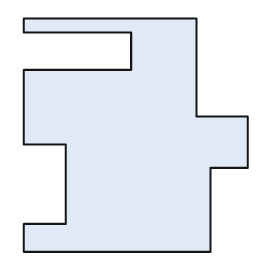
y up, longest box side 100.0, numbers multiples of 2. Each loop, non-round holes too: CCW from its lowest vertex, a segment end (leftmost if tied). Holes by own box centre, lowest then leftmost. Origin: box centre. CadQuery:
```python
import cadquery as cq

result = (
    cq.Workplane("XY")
    .moveTo(-48.0, -50.0)
    .lineTo(32.0, -50.0)
    .lineTo(32.0, -14.0)
    .lineTo(48.0, -14.0)
    .lineTo(48.0, 8.0)
    .lineTo(26.0, 8.0)
    .lineTo(26.0, 50.0)
    .lineTo(-48.0, 50.0)
    .lineTo(-48.0, 44.0)
    .lineTo(-2.0, 44.0)
    .lineTo(-2.0, 28.0)
    .lineTo(-48.0, 28.0)
    .lineTo(-48.0, -4.0)
    .lineTo(-30.0, -4.0)
    .lineTo(-30.0, -38.0)
    .lineTo(-48.0, -38.0)
    .close()
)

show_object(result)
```